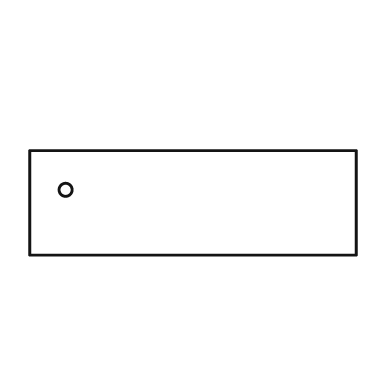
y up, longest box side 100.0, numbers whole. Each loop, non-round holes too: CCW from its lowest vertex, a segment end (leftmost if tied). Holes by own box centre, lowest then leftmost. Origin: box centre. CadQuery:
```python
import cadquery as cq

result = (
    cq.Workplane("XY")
    .moveTo(-50.0, -16.0)
    .lineTo(50.0, -16.0)
    .lineTo(50.0, 16.0)
    .lineTo(-50.0, 16.0)
    .close()
    .moveTo(-39.0, 4.0)
    .circle(2.0)
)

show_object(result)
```